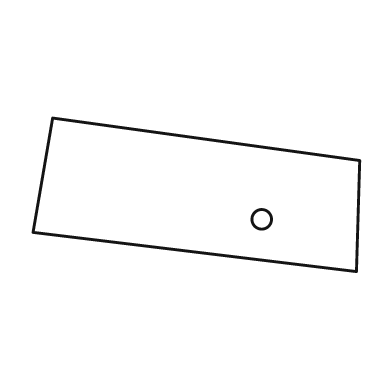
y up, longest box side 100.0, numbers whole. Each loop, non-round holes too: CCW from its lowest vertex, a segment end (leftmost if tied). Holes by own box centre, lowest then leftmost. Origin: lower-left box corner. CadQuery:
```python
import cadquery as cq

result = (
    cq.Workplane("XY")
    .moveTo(99.0, 0.0)
    .lineTo(100.0, 34.0)
    .lineTo(6.0, 47.0)
    .lineTo(0.0, 12.0)
    .close()
    .moveTo(70.0, 16.0)
    .circle(3.0)
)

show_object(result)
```